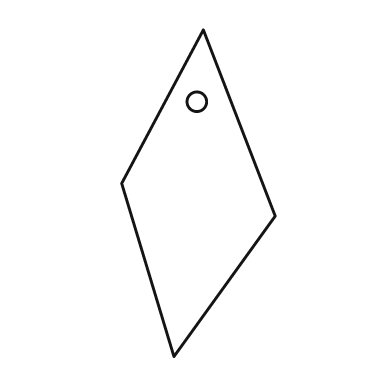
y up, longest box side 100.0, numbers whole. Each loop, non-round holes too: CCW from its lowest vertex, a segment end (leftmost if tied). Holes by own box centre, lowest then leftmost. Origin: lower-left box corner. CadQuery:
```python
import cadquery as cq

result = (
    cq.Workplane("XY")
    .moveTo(16.0, 0.0)
    .lineTo(47.0, 43.0)
    .lineTo(25.0, 100.0)
    .lineTo(0.0, 53.0)
    .close()
    .moveTo(23.0, 78.0)
    .circle(3.0)
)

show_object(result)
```